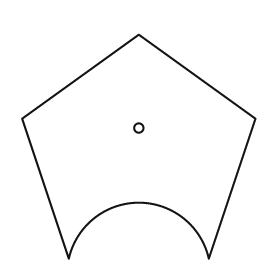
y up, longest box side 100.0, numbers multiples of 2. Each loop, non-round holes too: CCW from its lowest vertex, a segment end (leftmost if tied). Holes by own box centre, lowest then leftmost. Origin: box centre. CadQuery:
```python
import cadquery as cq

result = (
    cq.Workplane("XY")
    .moveTo(-30.0, -48.0)
    .threePointArc((0.0, -24.0), (30.0, -48.0))
    .lineTo(50.0, 12.0)
    .lineTo(0.0, 48.0)
    .lineTo(-50.0, 12.0)
    .close()
    .moveTo(0.0, 8.0)
    .circle(2.0)
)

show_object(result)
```